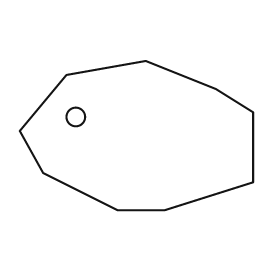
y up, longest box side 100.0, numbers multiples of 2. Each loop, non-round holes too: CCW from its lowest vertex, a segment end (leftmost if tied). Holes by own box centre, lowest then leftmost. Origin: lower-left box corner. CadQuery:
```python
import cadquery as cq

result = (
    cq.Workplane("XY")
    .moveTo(42.0, 0.0)
    .lineTo(62.0, 0.0)
    .lineTo(100.0, 12.0)
    .lineTo(100.0, 42.0)
    .lineTo(84.0, 52.0)
    .lineTo(54.0, 64.0)
    .lineTo(20.0, 58.0)
    .lineTo(0.0, 34.0)
    .lineTo(10.0, 16.0)
    .close()
    .moveTo(24.0, 40.0)
    .circle(4.0)
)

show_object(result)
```